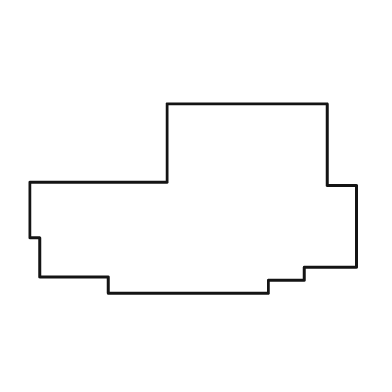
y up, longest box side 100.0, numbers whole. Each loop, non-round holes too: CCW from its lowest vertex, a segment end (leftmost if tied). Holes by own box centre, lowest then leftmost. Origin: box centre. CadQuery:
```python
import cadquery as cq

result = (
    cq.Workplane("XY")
    .moveTo(-26.0, -29.0)
    .lineTo(23.0, -29.0)
    .lineTo(23.0, -25.0)
    .lineTo(34.0, -25.0)
    .lineTo(34.0, -21.0)
    .lineTo(50.0, -21.0)
    .lineTo(50.0, 4.0)
    .lineTo(41.0, 4.0)
    .lineTo(41.0, 29.0)
    .lineTo(-8.0, 29.0)
    .lineTo(-8.0, 5.0)
    .lineTo(-50.0, 5.0)
    .lineTo(-50.0, -12.0)
    .lineTo(-47.0, -12.0)
    .lineTo(-47.0, -24.0)
    .lineTo(-26.0, -24.0)
    .close()
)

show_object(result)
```